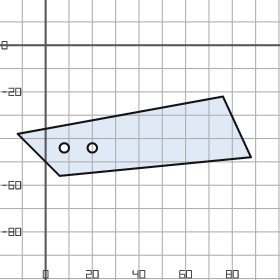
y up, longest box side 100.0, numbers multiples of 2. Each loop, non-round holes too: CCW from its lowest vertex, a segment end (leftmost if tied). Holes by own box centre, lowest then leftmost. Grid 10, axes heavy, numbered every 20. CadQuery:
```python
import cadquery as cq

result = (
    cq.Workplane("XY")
    .moveTo(6.0, -56.0)
    .lineTo(88.0, -48.0)
    .lineTo(76.0, -22.0)
    .lineTo(-12.0, -38.0)
    .close()
    .moveTo(8.0, -44.0)
    .circle(2.0)
    .moveTo(20.0, -44.0)
    .circle(2.0)
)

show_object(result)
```